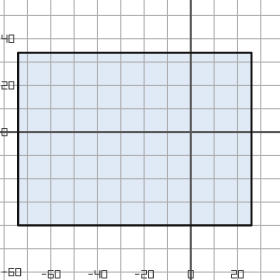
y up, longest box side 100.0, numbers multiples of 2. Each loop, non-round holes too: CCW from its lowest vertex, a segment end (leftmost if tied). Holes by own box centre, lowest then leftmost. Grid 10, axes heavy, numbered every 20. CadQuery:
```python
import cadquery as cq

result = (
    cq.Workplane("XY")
    .moveTo(-74.0, -40.0)
    .lineTo(26.0, -40.0)
    .lineTo(26.0, 34.0)
    .lineTo(-74.0, 34.0)
    .close()
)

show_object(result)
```